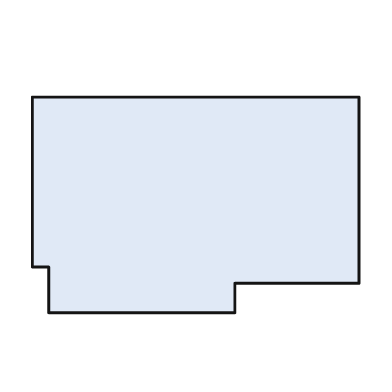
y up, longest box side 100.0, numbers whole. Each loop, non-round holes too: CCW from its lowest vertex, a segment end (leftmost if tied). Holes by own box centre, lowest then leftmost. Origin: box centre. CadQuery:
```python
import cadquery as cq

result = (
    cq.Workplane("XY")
    .moveTo(-45.0, -33.0)
    .lineTo(12.0, -33.0)
    .lineTo(12.0, -24.0)
    .lineTo(50.0, -24.0)
    .lineTo(50.0, 33.0)
    .lineTo(-50.0, 33.0)
    .lineTo(-50.0, -19.0)
    .lineTo(-45.0, -19.0)
    .close()
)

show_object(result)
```